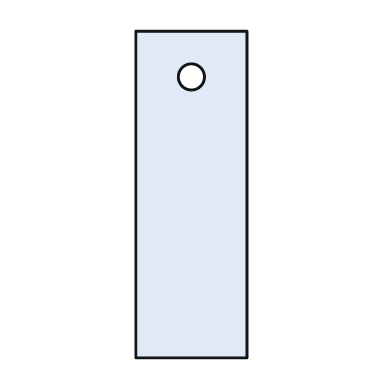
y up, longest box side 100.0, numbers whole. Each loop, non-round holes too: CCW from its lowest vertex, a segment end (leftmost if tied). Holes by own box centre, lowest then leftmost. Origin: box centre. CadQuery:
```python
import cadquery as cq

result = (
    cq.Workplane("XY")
    .moveTo(-17.0, -50.0)
    .lineTo(17.0, -50.0)
    .lineTo(17.0, 50.0)
    .lineTo(-17.0, 50.0)
    .close()
    .moveTo(0.0, 36.0)
    .circle(4.0)
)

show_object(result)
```